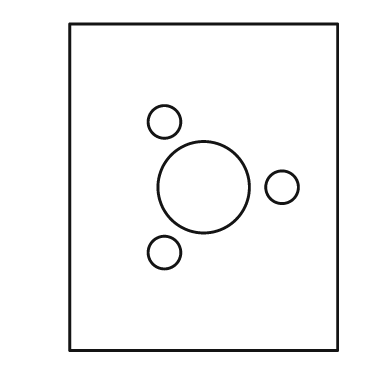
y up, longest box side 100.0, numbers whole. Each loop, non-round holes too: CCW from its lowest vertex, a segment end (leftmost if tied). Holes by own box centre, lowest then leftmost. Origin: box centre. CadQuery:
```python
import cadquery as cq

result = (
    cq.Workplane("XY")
    .moveTo(-41.0, -50.0)
    .lineTo(41.0, -50.0)
    .lineTo(41.0, 50.0)
    .lineTo(-41.0, 50.0)
    .close()
    .moveTo(-12.0, -20.0)
    .circle(5.0)
    .moveTo(0.0, 0.0)
    .circle(14.0)
    .moveTo(24.0, 0.0)
    .circle(5.0)
    .moveTo(-12.0, 20.0)
    .circle(5.0)
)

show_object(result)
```